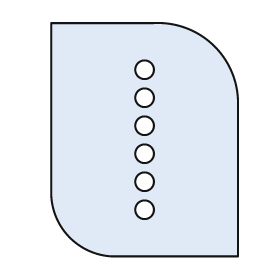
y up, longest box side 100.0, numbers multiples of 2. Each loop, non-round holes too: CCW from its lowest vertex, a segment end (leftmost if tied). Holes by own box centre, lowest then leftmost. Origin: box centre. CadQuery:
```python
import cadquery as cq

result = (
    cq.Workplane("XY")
    .moveTo(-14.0, -50.0)
    .lineTo(40.0, -50.0)
    .lineTo(40.0, 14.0)
    .threePointArc((30.0, 40.0), (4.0, 50.0))
    .lineTo(-40.0, 50.0)
    .lineTo(-40.0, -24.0)
    .threePointArc((-32.0, -42.0), (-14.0, -50.0))
    .close()
    .moveTo(0.0, -30.0)
    .circle(4.0)
    .moveTo(0.0, -18.0)
    .circle(4.0)
    .moveTo(0.0, -6.0)
    .circle(4.0)
    .moveTo(0.0, 6.0)
    .circle(4.0)
    .moveTo(0.0, 18.0)
    .circle(4.0)
    .moveTo(0.0, 30.0)
    .circle(4.0)
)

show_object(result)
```